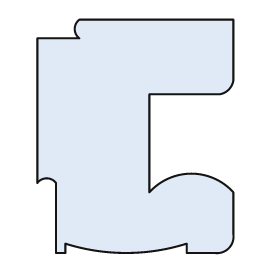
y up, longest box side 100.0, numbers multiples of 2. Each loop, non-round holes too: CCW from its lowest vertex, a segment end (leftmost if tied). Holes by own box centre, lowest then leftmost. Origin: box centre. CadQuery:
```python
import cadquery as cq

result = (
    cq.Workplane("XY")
    .moveTo(-34.0, -50.0)
    .lineTo(-30.0, -50.0)
    .lineTo(-30.0, -46.0)
    .threePointArc((-4.0, -50.0), (22.0, -46.0))
    .lineTo(22.0, -50.0)
    .lineTo(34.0, -50.0)
    .threePointArc((40.0, -48.0), (42.0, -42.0))
    .lineTo(42.0, -24.0)
    .threePointArc((24.0, -16.0), (6.0, -24.0))
    .lineTo(6.0, 18.0)
    .lineTo(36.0, 18.0)
    .threePointArc((40.0, 20.0), (42.0, 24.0))
    .lineTo(42.0, 50.0)
    .lineTo(-24.0, 50.0)
    .threePointArc((-26.0, 46.0), (-24.0, 42.0))
    .lineTo(-42.0, 42.0)
    .lineTo(-42.0, -20.0)
    .threePointArc((-38.0, -18.0), (-34.0, -20.0))
    .close()
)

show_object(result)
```